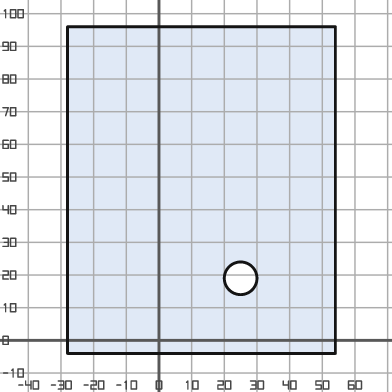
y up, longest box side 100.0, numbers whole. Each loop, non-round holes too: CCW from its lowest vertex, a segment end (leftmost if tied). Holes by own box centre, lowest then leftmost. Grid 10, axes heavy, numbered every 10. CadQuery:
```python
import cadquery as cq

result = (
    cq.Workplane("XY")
    .moveTo(-28.0, -4.0)
    .lineTo(54.0, -4.0)
    .lineTo(54.0, 96.0)
    .lineTo(-28.0, 96.0)
    .close()
    .moveTo(25.0, 19.0)
    .circle(5.0)
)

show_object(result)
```